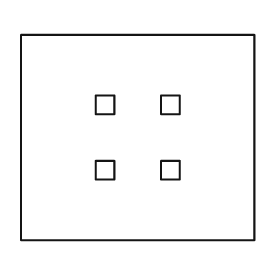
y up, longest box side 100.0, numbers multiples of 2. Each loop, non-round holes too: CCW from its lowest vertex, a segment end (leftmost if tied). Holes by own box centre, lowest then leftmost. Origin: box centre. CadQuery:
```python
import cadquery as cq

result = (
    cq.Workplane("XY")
    .moveTo(-50.0, -44.0)
    .lineTo(50.0, -44.0)
    .lineTo(50.0, 44.0)
    .lineTo(-50.0, 44.0)
    .close()
    .moveTo(-18.0, -18.0)
    .lineTo(-10.0, -18.0)
    .lineTo(-10.0, -10.0)
    .lineTo(-18.0, -10.0)
    .close()
    .moveTo(10.0, -18.0)
    .lineTo(18.0, -18.0)
    .lineTo(18.0, -10.0)
    .lineTo(10.0, -10.0)
    .close()
    .moveTo(-18.0, 10.0)
    .lineTo(-10.0, 10.0)
    .lineTo(-10.0, 18.0)
    .lineTo(-18.0, 18.0)
    .close()
    .moveTo(10.0, 10.0)
    .lineTo(18.0, 10.0)
    .lineTo(18.0, 18.0)
    .lineTo(10.0, 18.0)
    .close()
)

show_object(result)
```